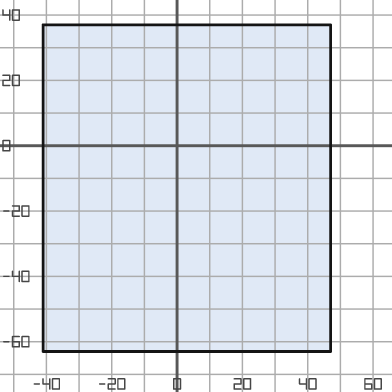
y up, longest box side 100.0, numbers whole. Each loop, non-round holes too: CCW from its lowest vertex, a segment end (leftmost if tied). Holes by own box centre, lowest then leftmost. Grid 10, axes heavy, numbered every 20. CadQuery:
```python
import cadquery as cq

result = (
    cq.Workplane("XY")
    .moveTo(-41.0, -63.0)
    .lineTo(47.0, -63.0)
    .lineTo(47.0, 37.0)
    .lineTo(-41.0, 37.0)
    .close()
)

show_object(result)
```